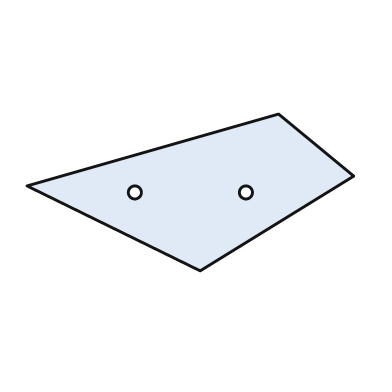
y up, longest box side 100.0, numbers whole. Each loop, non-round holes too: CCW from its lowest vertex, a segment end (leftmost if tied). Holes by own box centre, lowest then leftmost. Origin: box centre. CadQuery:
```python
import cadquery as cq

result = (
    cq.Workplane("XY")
    .moveTo(3.0, -24.0)
    .lineTo(50.0, 5.0)
    .lineTo(27.0, 24.0)
    .lineTo(-50.0, 2.0)
    .close()
    .moveTo(-17.0, 0.0)
    .circle(2.0)
    .moveTo(17.0, 0.0)
    .circle(2.0)
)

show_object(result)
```